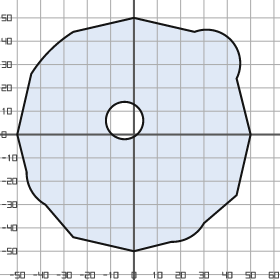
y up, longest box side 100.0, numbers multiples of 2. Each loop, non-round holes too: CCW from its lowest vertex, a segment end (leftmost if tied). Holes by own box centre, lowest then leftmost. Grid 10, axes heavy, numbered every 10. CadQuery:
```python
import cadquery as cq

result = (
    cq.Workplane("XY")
    .moveTo(0.0, -50.0)
    .lineTo(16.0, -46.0)
    .threePointArc((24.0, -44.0), (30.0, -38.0))
    .lineTo(44.0, -26.0)
    .lineTo(50.0, 0.0)
    .lineTo(44.0, 24.0)
    .threePointArc((42.0, 40.0), (26.0, 44.0))
    .lineTo(0.0, 50.0)
    .lineTo(-26.0, 44.0)
    .threePointArc((-36.0, 36.0), (-44.0, 26.0))
    .lineTo(-50.0, 0.0)
    .lineTo(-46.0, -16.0)
    .threePointArc((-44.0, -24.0), (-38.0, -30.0))
    .lineTo(-26.0, -44.0)
    .close()
    .moveTo(-4.0, 6.0)
    .circle(8.0)
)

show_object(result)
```